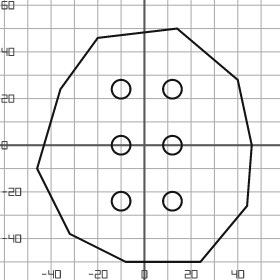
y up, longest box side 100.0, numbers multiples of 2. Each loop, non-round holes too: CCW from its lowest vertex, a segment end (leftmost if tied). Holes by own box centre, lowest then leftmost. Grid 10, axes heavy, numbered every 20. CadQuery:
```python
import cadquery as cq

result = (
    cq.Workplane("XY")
    .moveTo(-8.0, -50.0)
    .lineTo(24.0, -50.0)
    .lineTo(44.0, -26.0)
    .lineTo(46.0, 0.0)
    .lineTo(40.0, 28.0)
    .lineTo(14.0, 50.0)
    .lineTo(-20.0, 46.0)
    .lineTo(-36.0, 24.0)
    .lineTo(-46.0, -10.0)
    .lineTo(-32.0, -38.0)
    .close()
    .moveTo(-10.0, -24.0)
    .circle(4.0)
    .moveTo(12.0, -24.0)
    .circle(4.0)
    .moveTo(-10.0, 0.0)
    .circle(4.0)
    .moveTo(12.0, 0.0)
    .circle(4.0)
    .moveTo(-10.0, 24.0)
    .circle(4.0)
    .moveTo(12.0, 24.0)
    .circle(4.0)
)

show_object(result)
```